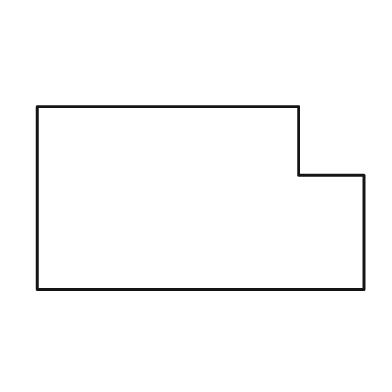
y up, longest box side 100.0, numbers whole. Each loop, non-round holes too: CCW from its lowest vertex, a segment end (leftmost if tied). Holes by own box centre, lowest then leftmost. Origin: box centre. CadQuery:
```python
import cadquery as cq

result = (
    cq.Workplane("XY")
    .moveTo(-50.0, -28.0)
    .lineTo(50.0, -28.0)
    .lineTo(50.0, 7.0)
    .lineTo(30.0, 7.0)
    .lineTo(30.0, 28.0)
    .lineTo(-50.0, 28.0)
    .close()
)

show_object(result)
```